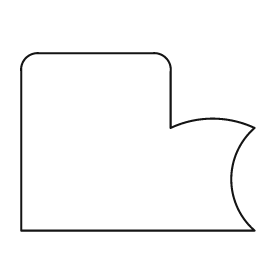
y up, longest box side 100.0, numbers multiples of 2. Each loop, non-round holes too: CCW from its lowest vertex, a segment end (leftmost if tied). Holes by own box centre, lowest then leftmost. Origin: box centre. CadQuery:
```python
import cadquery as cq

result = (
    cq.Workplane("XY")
    .moveTo(-50.0, -38.0)
    .lineTo(50.0, -38.0)
    .threePointArc((40.0, -16.0), (50.0, 6.0))
    .threePointArc((32.0, 10.0), (14.0, 6.0))
    .lineTo(14.0, 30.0)
    .threePointArc((12.0, 36.0), (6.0, 38.0))
    .lineTo(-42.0, 38.0)
    .threePointArc((-48.0, 36.0), (-50.0, 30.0))
    .close()
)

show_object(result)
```